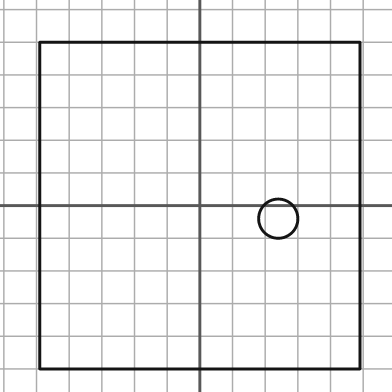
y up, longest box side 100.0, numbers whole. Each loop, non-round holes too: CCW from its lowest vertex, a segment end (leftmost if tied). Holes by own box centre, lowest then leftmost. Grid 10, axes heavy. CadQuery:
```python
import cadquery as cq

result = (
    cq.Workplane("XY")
    .moveTo(-49.0, -50.0)
    .lineTo(49.0, -50.0)
    .lineTo(49.0, 50.0)
    .lineTo(-49.0, 50.0)
    .close()
    .moveTo(24.0, -4.0)
    .circle(6.0)
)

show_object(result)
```